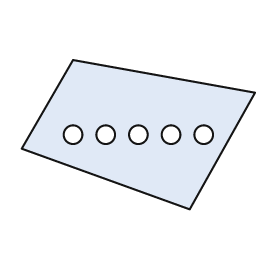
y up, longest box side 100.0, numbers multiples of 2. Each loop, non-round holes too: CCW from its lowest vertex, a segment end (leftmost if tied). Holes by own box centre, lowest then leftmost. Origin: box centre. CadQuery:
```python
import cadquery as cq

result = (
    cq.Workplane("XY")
    .moveTo(22.0, -32.0)
    .lineTo(50.0, 18.0)
    .lineTo(-28.0, 32.0)
    .lineTo(-50.0, -6.0)
    .close()
    .moveTo(-28.0, 0.0)
    .circle(4.0)
    .moveTo(-14.0, 0.0)
    .circle(4.0)
    .moveTo(0.0, 0.0)
    .circle(4.0)
    .moveTo(14.0, 0.0)
    .circle(4.0)
    .moveTo(28.0, 0.0)
    .circle(4.0)
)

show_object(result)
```